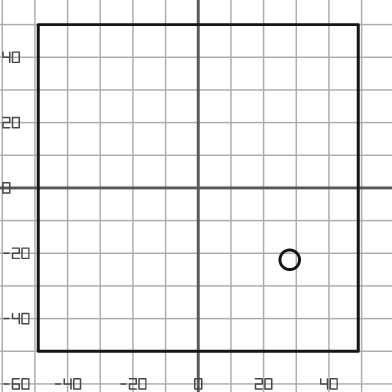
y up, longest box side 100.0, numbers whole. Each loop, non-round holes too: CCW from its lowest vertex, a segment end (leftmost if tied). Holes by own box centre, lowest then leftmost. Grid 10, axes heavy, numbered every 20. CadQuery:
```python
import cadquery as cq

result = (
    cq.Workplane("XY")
    .moveTo(-49.0, -50.0)
    .lineTo(49.0, -50.0)
    .lineTo(49.0, 50.0)
    .lineTo(-49.0, 50.0)
    .close()
    .moveTo(28.0, -22.0)
    .circle(3.0)
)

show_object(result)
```